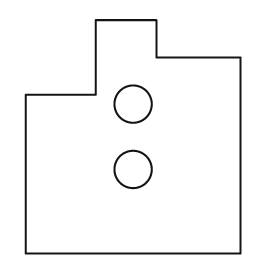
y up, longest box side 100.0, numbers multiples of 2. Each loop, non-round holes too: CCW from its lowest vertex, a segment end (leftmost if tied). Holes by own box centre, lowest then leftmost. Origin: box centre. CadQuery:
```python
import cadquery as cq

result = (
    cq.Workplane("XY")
    .moveTo(-46.0, -50.0)
    .lineTo(46.0, -50.0)
    .lineTo(46.0, 34.0)
    .lineTo(10.0, 34.0)
    .lineTo(10.0, 50.0)
    .lineTo(-16.0, 50.0)
    .lineTo(-16.0, 18.0)
    .lineTo(-46.0, 18.0)
    .close()
    .moveTo(0.0, -14.0)
    .circle(8.0)
    .moveTo(0.0, 14.0)
    .circle(8.0)
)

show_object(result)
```